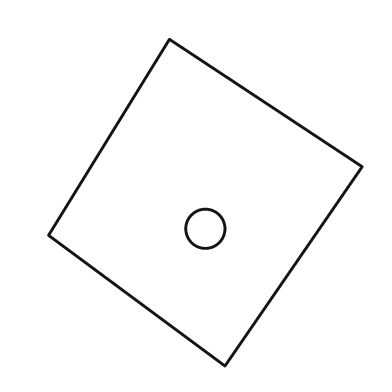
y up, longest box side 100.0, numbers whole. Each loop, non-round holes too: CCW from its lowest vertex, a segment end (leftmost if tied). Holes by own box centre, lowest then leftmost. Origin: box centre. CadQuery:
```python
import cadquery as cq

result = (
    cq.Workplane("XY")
    .moveTo(6.0, -50.0)
    .lineTo(48.0, 11.0)
    .lineTo(-11.0, 50.0)
    .lineTo(-48.0, -10.0)
    .close()
    .moveTo(0.0, -8.0)
    .circle(6.0)
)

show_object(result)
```